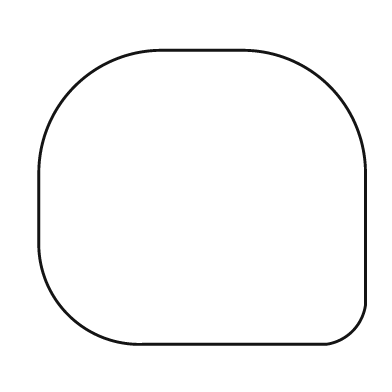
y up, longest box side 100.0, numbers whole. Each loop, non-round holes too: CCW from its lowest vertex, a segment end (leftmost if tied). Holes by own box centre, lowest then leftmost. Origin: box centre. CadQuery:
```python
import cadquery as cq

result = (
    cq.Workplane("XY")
    .moveTo(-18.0, -45.0)
    .lineTo(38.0, -45.0)
    .threePointArc((46.0, -41.0), (50.0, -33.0))
    .lineTo(50.0, 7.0)
    .threePointArc((39.0, 34.0), (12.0, 45.0))
    .lineTo(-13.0, 45.0)
    .threePointArc((-39.0, 34.0), (-50.0, 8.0))
    .lineTo(-50.0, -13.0)
    .threePointArc((-41.0, -36.0), (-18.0, -45.0))
    .close()
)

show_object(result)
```